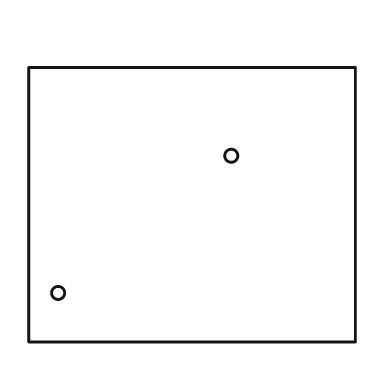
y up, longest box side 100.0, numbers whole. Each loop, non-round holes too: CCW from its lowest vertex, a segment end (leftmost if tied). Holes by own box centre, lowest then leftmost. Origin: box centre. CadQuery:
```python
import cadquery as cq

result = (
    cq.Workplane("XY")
    .moveTo(-50.0, -42.0)
    .lineTo(50.0, -42.0)
    .lineTo(50.0, 42.0)
    .lineTo(-50.0, 42.0)
    .close()
    .moveTo(-41.0, -27.0)
    .circle(2.0)
    .moveTo(12.0, 15.0)
    .circle(2.0)
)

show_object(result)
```